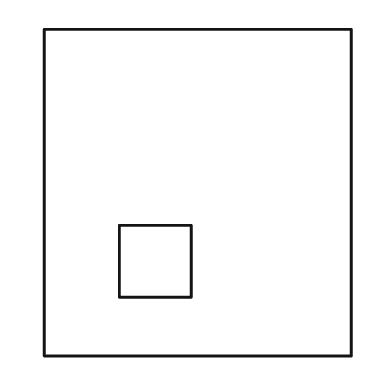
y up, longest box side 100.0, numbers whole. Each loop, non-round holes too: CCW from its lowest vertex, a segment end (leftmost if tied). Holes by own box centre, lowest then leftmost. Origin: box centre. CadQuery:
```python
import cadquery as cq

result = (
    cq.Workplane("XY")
    .moveTo(-47.0, -50.0)
    .lineTo(47.0, -50.0)
    .lineTo(47.0, 50.0)
    .lineTo(-47.0, 50.0)
    .close()
    .moveTo(-24.0, -32.0)
    .lineTo(-2.0, -32.0)
    .lineTo(-2.0, -10.0)
    .lineTo(-24.0, -10.0)
    .close()
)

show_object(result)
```